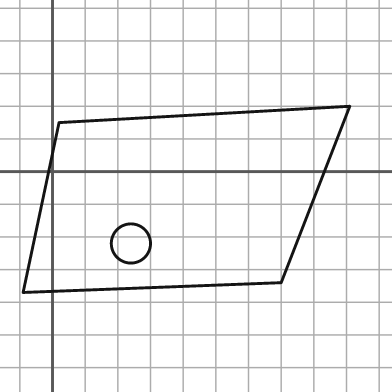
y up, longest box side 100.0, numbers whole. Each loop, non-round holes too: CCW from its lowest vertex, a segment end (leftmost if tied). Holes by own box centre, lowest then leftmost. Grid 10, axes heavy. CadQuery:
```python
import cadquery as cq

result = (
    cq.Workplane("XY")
    .moveTo(-9.0, -37.0)
    .lineTo(70.0, -34.0)
    .lineTo(91.0, 20.0)
    .lineTo(2.0, 15.0)
    .close()
    .moveTo(24.0, -22.0)
    .circle(6.0)
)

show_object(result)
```